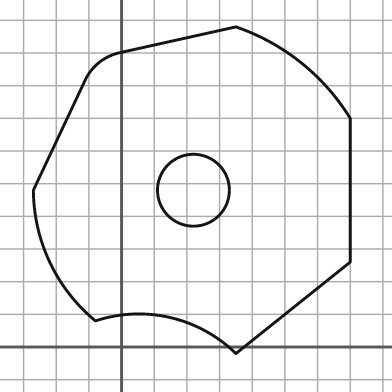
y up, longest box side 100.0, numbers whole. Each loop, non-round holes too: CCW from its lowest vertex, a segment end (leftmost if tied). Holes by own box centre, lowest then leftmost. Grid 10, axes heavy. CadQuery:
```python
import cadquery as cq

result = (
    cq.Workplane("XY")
    .moveTo(35.0, -2.0)
    .lineTo(70.0, 26.0)
    .lineTo(70.0, 70.0)
    .threePointArc((55.0, 87.0), (35.0, 98.0))
    .lineTo(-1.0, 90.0)
    .threePointArc((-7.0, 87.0), (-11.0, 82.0))
    .lineTo(-27.0, 48.0)
    .threePointArc((-22.0, 26.0), (-8.0, 8.0))
    .threePointArc((15.0, 9.0), (35.0, -2.0))
    .close()
    .moveTo(22.0, 48.0)
    .circle(11.0)
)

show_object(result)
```